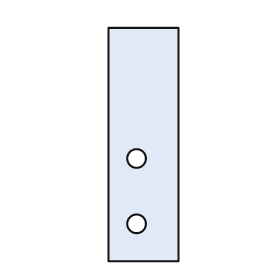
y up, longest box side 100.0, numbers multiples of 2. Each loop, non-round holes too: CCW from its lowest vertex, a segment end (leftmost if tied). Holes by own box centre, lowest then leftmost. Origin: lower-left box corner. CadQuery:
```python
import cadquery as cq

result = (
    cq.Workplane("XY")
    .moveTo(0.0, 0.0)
    .lineTo(30.0, 0.0)
    .lineTo(30.0, 100.0)
    .lineTo(0.0, 100.0)
    .close()
    .moveTo(12.0, 16.0)
    .circle(4.0)
    .moveTo(12.0, 44.0)
    .circle(4.0)
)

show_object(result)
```